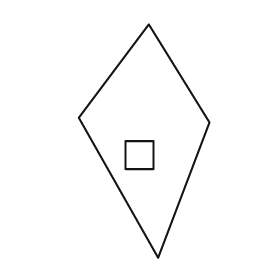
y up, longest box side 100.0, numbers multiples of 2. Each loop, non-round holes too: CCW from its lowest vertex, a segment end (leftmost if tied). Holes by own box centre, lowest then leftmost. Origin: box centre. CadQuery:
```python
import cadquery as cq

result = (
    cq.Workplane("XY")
    .moveTo(6.0, -50.0)
    .lineTo(28.0, 8.0)
    .lineTo(2.0, 50.0)
    .lineTo(-28.0, 10.0)
    .close()
    .moveTo(-8.0, -12.0)
    .lineTo(4.0, -12.0)
    .lineTo(4.0, 0.0)
    .lineTo(-8.0, 0.0)
    .close()
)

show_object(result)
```